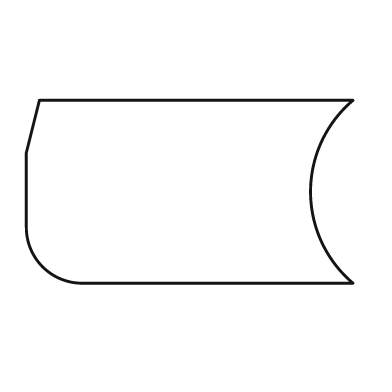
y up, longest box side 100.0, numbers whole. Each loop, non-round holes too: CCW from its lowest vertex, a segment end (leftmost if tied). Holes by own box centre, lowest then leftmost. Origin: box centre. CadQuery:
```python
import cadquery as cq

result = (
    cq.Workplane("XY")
    .moveTo(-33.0, -28.0)
    .lineTo(50.0, -28.0)
    .threePointArc((37.0, 0.0), (50.0, 28.0))
    .lineTo(-46.0, 28.0)
    .lineTo(-50.0, 12.0)
    .lineTo(-50.0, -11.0)
    .threePointArc((-45.0, -23.0), (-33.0, -28.0))
    .close()
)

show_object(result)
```